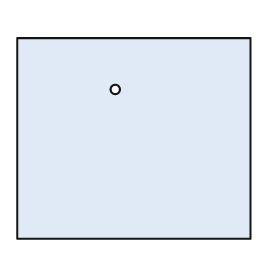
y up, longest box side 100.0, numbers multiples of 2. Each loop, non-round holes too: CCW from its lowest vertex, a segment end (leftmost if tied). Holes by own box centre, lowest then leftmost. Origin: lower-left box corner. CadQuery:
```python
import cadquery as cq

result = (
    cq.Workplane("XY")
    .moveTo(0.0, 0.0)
    .lineTo(100.0, 0.0)
    .lineTo(100.0, 86.0)
    .lineTo(0.0, 86.0)
    .close()
    .moveTo(42.0, 64.0)
    .circle(2.0)
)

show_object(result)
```